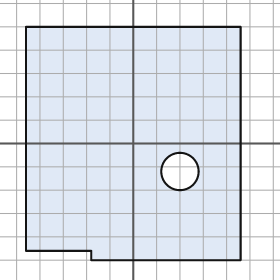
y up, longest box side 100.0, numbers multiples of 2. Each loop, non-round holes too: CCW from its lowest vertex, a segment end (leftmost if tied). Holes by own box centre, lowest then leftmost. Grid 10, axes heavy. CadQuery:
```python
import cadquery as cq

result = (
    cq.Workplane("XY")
    .moveTo(-18.0, -50.0)
    .lineTo(46.0, -50.0)
    .lineTo(46.0, 50.0)
    .lineTo(-46.0, 50.0)
    .lineTo(-46.0, -46.0)
    .lineTo(-18.0, -46.0)
    .close()
    .moveTo(20.0, -12.0)
    .circle(8.0)
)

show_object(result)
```